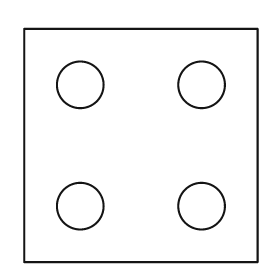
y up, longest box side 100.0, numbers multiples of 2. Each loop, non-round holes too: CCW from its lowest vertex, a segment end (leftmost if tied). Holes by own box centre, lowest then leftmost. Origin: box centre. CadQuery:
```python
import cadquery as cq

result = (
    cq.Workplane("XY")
    .moveTo(-50.0, -50.0)
    .lineTo(50.0, -50.0)
    .lineTo(50.0, 50.0)
    .lineTo(-50.0, 50.0)
    .close()
    .moveTo(-26.0, -26.0)
    .circle(10.0)
    .moveTo(26.0, -26.0)
    .circle(10.0)
    .moveTo(-26.0, 26.0)
    .circle(10.0)
    .moveTo(26.0, 26.0)
    .circle(10.0)
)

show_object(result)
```